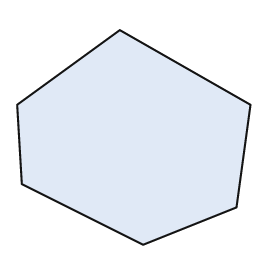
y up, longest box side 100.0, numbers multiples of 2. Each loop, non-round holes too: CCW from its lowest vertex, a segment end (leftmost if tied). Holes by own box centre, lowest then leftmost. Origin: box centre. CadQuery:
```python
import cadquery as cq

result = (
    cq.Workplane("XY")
    .moveTo(4.0, -46.0)
    .lineTo(44.0, -30.0)
    .lineTo(50.0, 14.0)
    .lineTo(-6.0, 46.0)
    .lineTo(-50.0, 14.0)
    .lineTo(-48.0, -20.0)
    .close()
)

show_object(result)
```